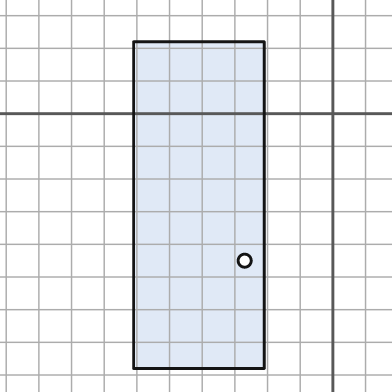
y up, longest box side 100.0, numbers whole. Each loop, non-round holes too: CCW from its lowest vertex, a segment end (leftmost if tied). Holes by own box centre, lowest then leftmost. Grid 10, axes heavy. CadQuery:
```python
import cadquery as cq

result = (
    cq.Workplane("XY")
    .moveTo(-61.0, -78.0)
    .lineTo(-21.0, -78.0)
    .lineTo(-21.0, 22.0)
    .lineTo(-61.0, 22.0)
    .close()
    .moveTo(-27.0, -45.0)
    .circle(2.0)
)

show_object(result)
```